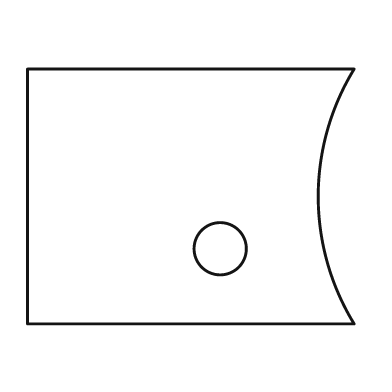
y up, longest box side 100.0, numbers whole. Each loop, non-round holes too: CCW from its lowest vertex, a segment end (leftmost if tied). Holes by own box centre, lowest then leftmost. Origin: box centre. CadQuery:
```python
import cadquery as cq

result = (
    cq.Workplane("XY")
    .moveTo(-50.0, -39.0)
    .lineTo(50.0, -39.0)
    .threePointArc((39.0, 0.0), (50.0, 39.0))
    .lineTo(-50.0, 39.0)
    .close()
    .moveTo(9.0, -16.0)
    .circle(8.0)
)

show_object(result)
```